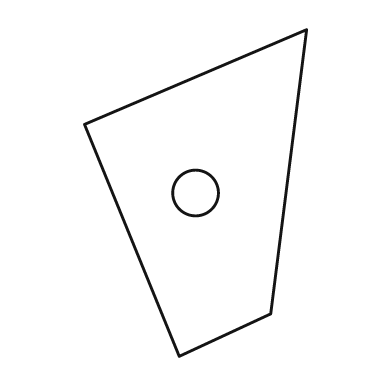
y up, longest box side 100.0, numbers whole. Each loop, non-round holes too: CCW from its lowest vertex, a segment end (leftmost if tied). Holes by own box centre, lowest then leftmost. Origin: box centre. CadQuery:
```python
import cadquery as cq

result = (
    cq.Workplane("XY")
    .moveTo(-5.0, -50.0)
    .lineTo(23.0, -37.0)
    .lineTo(34.0, 50.0)
    .lineTo(-34.0, 21.0)
    .close()
    .moveTo(0.0, 0.0)
    .circle(7.0)
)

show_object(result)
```